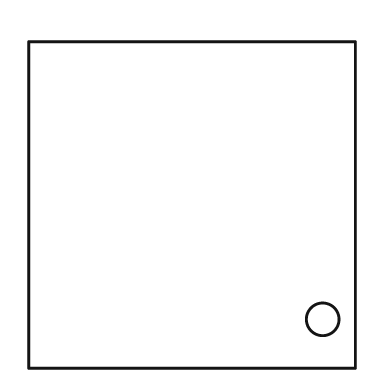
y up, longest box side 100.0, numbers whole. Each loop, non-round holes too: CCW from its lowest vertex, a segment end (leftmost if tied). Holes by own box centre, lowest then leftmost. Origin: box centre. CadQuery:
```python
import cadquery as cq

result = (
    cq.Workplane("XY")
    .moveTo(-50.0, -50.0)
    .lineTo(50.0, -50.0)
    .lineTo(50.0, 50.0)
    .lineTo(-50.0, 50.0)
    .close()
    .moveTo(40.0, -35.0)
    .circle(5.0)
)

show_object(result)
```